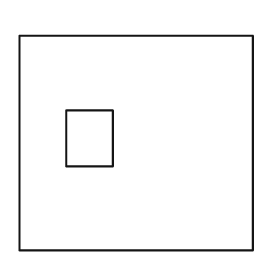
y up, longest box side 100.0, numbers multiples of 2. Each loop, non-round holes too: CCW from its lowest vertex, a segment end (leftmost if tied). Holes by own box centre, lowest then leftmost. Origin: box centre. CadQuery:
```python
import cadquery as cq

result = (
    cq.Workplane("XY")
    .moveTo(-50.0, -46.0)
    .lineTo(50.0, -46.0)
    .lineTo(50.0, 46.0)
    .lineTo(-50.0, 46.0)
    .close()
    .moveTo(-30.0, -10.0)
    .lineTo(-10.0, -10.0)
    .lineTo(-10.0, 14.0)
    .lineTo(-30.0, 14.0)
    .close()
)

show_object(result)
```